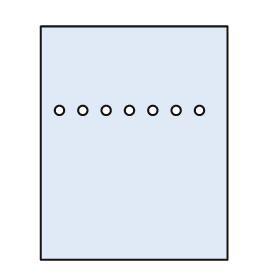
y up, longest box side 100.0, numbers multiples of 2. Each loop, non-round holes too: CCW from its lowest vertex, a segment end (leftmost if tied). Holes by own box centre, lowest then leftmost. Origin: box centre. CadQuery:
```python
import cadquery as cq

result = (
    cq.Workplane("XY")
    .moveTo(-40.0, -50.0)
    .lineTo(40.0, -50.0)
    .lineTo(40.0, 50.0)
    .lineTo(-40.0, 50.0)
    .close()
    .moveTo(-32.0, 14.0)
    .circle(2.0)
    .moveTo(-22.0, 14.0)
    .circle(2.0)
    .moveTo(-12.0, 14.0)
    .circle(2.0)
    .moveTo(-2.0, 14.0)
    .circle(2.0)
    .moveTo(8.0, 14.0)
    .circle(2.0)
    .moveTo(18.0, 14.0)
    .circle(2.0)
    .moveTo(28.0, 14.0)
    .circle(2.0)
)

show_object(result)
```